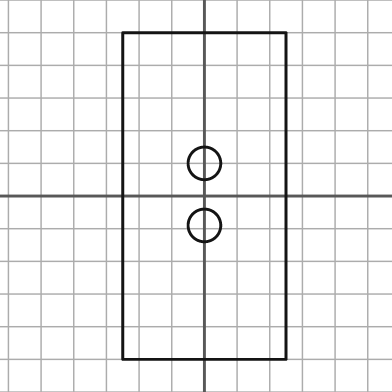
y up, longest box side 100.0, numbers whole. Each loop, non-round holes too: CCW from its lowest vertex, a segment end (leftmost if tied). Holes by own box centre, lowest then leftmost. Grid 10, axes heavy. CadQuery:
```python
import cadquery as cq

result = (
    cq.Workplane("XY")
    .moveTo(-25.0, -50.0)
    .lineTo(25.0, -50.0)
    .lineTo(25.0, 50.0)
    .lineTo(-25.0, 50.0)
    .close()
    .moveTo(0.0, -9.0)
    .circle(5.0)
    .moveTo(0.0, 10.0)
    .circle(5.0)
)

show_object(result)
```